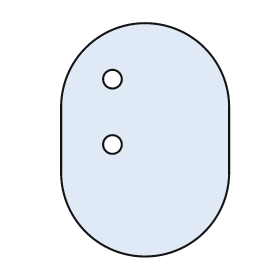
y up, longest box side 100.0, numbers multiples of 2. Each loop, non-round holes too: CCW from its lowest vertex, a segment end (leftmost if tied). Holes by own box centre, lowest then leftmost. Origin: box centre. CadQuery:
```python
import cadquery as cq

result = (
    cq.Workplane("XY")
    .moveTo(-36.0, -14.0)
    .threePointArc((0.0, -50.0), (36.0, -14.0))
    .lineTo(36.0, 14.0)
    .threePointArc((0.0, 50.0), (-36.0, 14.0))
    .close()
    .moveTo(-14.0, -2.0)
    .circle(4.0)
    .moveTo(-14.0, 26.0)
    .circle(4.0)
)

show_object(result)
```